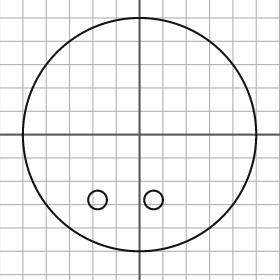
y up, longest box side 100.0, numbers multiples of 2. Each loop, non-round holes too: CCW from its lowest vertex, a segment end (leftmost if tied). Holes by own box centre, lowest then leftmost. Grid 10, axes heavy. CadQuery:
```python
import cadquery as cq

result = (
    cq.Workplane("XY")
    .moveTo(0.0, 0.0)
    .circle(50.0)
    .moveTo(-18.0, -28.0)
    .circle(4.0)
    .moveTo(6.0, -28.0)
    .circle(4.0)
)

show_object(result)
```